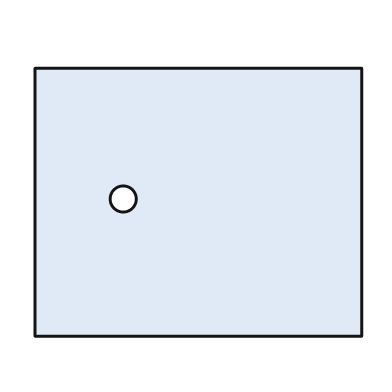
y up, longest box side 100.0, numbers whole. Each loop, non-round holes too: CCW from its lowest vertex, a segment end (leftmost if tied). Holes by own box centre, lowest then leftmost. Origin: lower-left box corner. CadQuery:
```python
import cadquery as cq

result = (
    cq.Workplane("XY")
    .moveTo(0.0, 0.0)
    .lineTo(100.0, 0.0)
    .lineTo(100.0, 82.0)
    .lineTo(0.0, 82.0)
    .close()
    .moveTo(27.0, 42.0)
    .circle(4.0)
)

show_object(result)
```